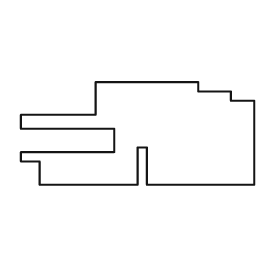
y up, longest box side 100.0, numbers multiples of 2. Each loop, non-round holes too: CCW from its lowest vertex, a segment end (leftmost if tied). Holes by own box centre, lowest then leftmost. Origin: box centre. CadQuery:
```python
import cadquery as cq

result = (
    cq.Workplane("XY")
    .moveTo(-42.0, -22.0)
    .lineTo(0.0, -22.0)
    .lineTo(0.0, -6.0)
    .lineTo(4.0, -6.0)
    .lineTo(4.0, -22.0)
    .lineTo(50.0, -22.0)
    .lineTo(50.0, 14.0)
    .lineTo(40.0, 14.0)
    .lineTo(40.0, 18.0)
    .lineTo(26.0, 18.0)
    .lineTo(26.0, 22.0)
    .lineTo(-18.0, 22.0)
    .lineTo(-18.0, 8.0)
    .lineTo(-50.0, 8.0)
    .lineTo(-50.0, 2.0)
    .lineTo(-10.0, 2.0)
    .lineTo(-10.0, -8.0)
    .lineTo(-50.0, -8.0)
    .lineTo(-50.0, -12.0)
    .lineTo(-42.0, -12.0)
    .close()
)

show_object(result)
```